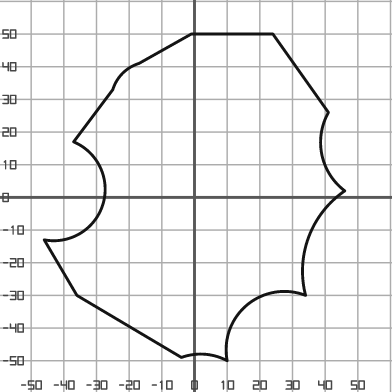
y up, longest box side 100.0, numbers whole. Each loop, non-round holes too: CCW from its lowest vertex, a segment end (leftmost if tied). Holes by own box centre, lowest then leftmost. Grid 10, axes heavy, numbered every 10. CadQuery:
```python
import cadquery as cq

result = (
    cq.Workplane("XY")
    .moveTo(10.0, -50.0)
    .threePointArc((16.0, -33.0), (34.0, -30.0))
    .threePointArc((35.0, -12.0), (46.0, 2.0))
    .threePointArc((39.0, 13.0), (41.0, 26.0))
    .lineTo(24.0, 50.0)
    .lineTo(-1.0, 50.0)
    .lineTo(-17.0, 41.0)
    .threePointArc((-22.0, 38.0), (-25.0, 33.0))
    .lineTo(-37.0, 17.0)
    .threePointArc((-28.0, -2.0), (-46.0, -13.0))
    .lineTo(-36.0, -30.0)
    .lineTo(-4.0, -49.0)
    .threePointArc((3.0, -48.0), (10.0, -50.0))
    .close()
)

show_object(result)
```